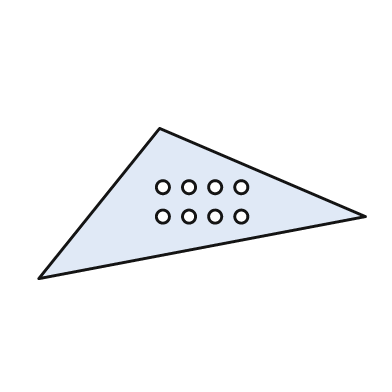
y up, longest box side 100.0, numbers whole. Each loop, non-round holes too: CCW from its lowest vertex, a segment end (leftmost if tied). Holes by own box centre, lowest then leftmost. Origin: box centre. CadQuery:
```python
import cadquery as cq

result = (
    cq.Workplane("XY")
    .moveTo(-50.0, -23.0)
    .lineTo(50.0, -4.0)
    .lineTo(-13.0, 23.0)
    .close()
    .moveTo(-12.0, -4.0)
    .circle(2.0)
    .moveTo(-4.0, -4.0)
    .circle(2.0)
    .moveTo(4.0, -4.0)
    .circle(2.0)
    .moveTo(12.0, -4.0)
    .circle(2.0)
    .moveTo(-12.0, 5.0)
    .circle(2.0)
    .moveTo(-4.0, 5.0)
    .circle(2.0)
    .moveTo(4.0, 5.0)
    .circle(2.0)
    .moveTo(12.0, 5.0)
    .circle(2.0)
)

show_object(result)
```